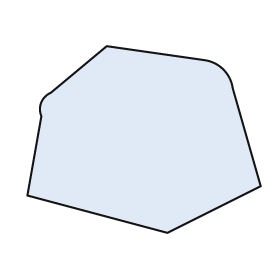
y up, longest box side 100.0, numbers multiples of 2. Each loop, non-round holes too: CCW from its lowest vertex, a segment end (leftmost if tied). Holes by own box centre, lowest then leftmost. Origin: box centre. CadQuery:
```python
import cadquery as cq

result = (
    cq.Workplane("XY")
    .moveTo(10.0, -40.0)
    .lineTo(50.0, -20.0)
    .lineTo(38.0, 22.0)
    .threePointArc((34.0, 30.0), (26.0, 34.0))
    .lineTo(-16.0, 40.0)
    .lineTo(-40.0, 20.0)
    .threePointArc((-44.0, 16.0), (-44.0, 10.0))
    .lineTo(-50.0, -24.0)
    .close()
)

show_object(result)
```